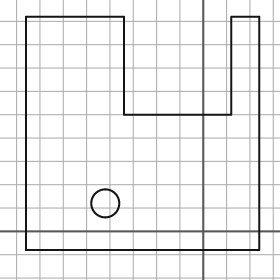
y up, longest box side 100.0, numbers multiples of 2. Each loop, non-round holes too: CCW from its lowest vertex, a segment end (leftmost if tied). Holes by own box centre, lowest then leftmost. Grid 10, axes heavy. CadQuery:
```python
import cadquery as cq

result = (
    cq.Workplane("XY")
    .moveTo(-76.0, -8.0)
    .lineTo(24.0, -8.0)
    .lineTo(24.0, 92.0)
    .lineTo(12.0, 92.0)
    .lineTo(12.0, 50.0)
    .lineTo(-34.0, 50.0)
    .lineTo(-34.0, 92.0)
    .lineTo(-76.0, 92.0)
    .close()
    .moveTo(-42.0, 12.0)
    .circle(6.0)
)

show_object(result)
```